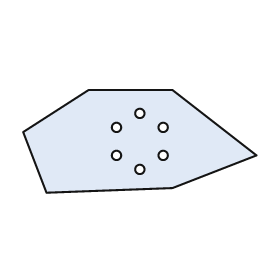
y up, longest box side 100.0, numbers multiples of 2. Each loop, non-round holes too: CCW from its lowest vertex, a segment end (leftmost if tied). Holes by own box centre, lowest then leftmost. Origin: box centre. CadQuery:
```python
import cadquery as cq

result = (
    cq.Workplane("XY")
    .moveTo(-40.0, -22.0)
    .lineTo(14.0, -20.0)
    .lineTo(50.0, -6.0)
    .lineTo(14.0, 22.0)
    .lineTo(-22.0, 22.0)
    .lineTo(-50.0, 4.0)
    .close()
    .moveTo(0.0, -12.0)
    .circle(2.0)
    .moveTo(-10.0, -6.0)
    .circle(2.0)
    .moveTo(10.0, -6.0)
    .circle(2.0)
    .moveTo(-10.0, 6.0)
    .circle(2.0)
    .moveTo(10.0, 6.0)
    .circle(2.0)
    .moveTo(0.0, 12.0)
    .circle(2.0)
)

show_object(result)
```